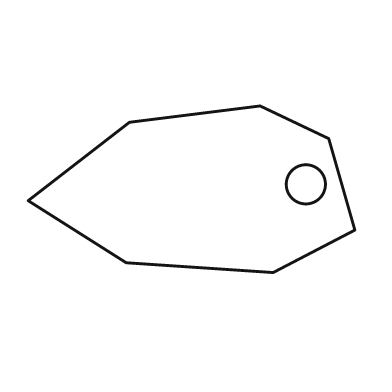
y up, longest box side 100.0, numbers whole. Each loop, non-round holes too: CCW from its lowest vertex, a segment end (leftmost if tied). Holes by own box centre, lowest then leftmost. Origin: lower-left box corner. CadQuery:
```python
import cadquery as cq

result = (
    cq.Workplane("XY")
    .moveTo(75.0, 0.0)
    .lineTo(100.0, 13.0)
    .lineTo(92.0, 41.0)
    .lineTo(71.0, 51.0)
    .lineTo(31.0, 46.0)
    .lineTo(0.0, 22.0)
    .lineTo(30.0, 3.0)
    .close()
    .moveTo(85.0, 27.0)
    .circle(6.0)
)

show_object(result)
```